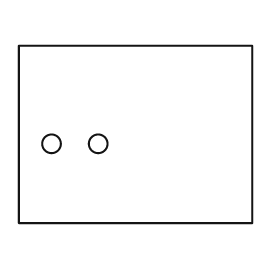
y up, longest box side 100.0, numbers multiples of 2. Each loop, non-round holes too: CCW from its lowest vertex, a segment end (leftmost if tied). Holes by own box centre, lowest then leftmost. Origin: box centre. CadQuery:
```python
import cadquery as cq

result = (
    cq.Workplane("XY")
    .moveTo(-50.0, -38.0)
    .lineTo(50.0, -38.0)
    .lineTo(50.0, 38.0)
    .lineTo(-50.0, 38.0)
    .close()
    .moveTo(-36.0, -4.0)
    .circle(4.0)
    .moveTo(-16.0, -4.0)
    .circle(4.0)
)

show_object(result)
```